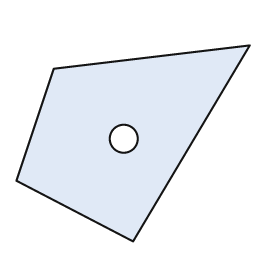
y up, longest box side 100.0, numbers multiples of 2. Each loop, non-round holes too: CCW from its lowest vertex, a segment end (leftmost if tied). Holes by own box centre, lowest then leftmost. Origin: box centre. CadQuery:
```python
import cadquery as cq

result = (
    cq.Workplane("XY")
    .moveTo(0.0, -42.0)
    .lineTo(50.0, 42.0)
    .lineTo(-34.0, 32.0)
    .lineTo(-50.0, -16.0)
    .close()
    .moveTo(-4.0, 2.0)
    .circle(6.0)
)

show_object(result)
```